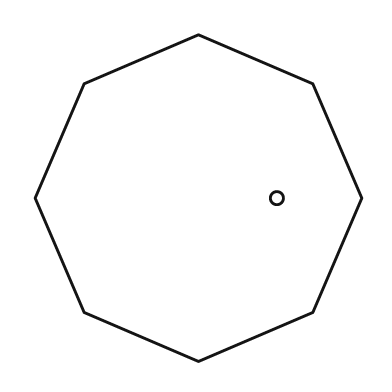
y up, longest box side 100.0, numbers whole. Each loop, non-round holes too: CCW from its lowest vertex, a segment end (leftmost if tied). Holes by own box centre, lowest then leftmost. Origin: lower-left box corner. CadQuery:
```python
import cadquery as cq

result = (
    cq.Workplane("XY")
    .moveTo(50.0, 0.0)
    .lineTo(85.0, 15.0)
    .lineTo(100.0, 50.0)
    .lineTo(85.0, 85.0)
    .lineTo(50.0, 100.0)
    .lineTo(15.0, 85.0)
    .lineTo(0.0, 50.0)
    .lineTo(15.0, 15.0)
    .close()
    .moveTo(74.0, 50.0)
    .circle(2.0)
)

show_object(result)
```